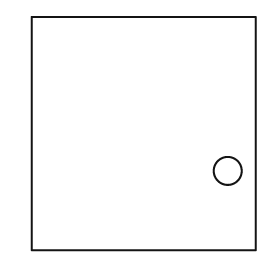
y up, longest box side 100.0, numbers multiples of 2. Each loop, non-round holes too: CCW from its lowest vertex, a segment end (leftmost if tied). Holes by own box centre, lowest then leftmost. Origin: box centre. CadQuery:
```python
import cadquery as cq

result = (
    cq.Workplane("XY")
    .moveTo(-48.0, -50.0)
    .lineTo(48.0, -50.0)
    .lineTo(48.0, 50.0)
    .lineTo(-48.0, 50.0)
    .close()
    .moveTo(36.0, -16.0)
    .circle(6.0)
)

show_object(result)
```